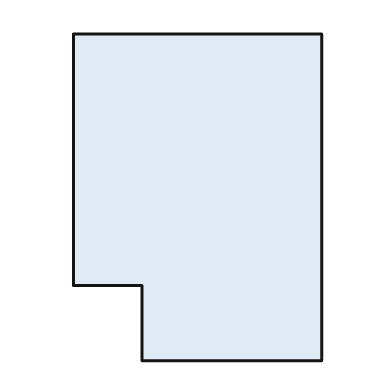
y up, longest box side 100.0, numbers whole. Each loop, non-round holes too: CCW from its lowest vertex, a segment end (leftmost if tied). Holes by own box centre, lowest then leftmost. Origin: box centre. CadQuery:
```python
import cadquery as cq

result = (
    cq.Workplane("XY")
    .moveTo(-17.0, -50.0)
    .lineTo(38.0, -50.0)
    .lineTo(38.0, 50.0)
    .lineTo(-38.0, 50.0)
    .lineTo(-38.0, -27.0)
    .lineTo(-17.0, -27.0)
    .close()
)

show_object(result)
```